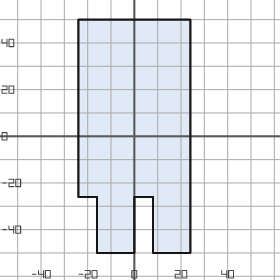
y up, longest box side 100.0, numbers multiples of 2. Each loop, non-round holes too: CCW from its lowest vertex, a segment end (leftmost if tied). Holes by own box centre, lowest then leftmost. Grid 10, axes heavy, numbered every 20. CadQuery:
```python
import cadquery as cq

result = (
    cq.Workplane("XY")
    .moveTo(-16.0, -50.0)
    .lineTo(0.0, -50.0)
    .lineTo(0.0, -26.0)
    .lineTo(8.0, -26.0)
    .lineTo(8.0, -50.0)
    .lineTo(24.0, -50.0)
    .lineTo(24.0, 50.0)
    .lineTo(-24.0, 50.0)
    .lineTo(-24.0, -26.0)
    .lineTo(-16.0, -26.0)
    .close()
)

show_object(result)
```